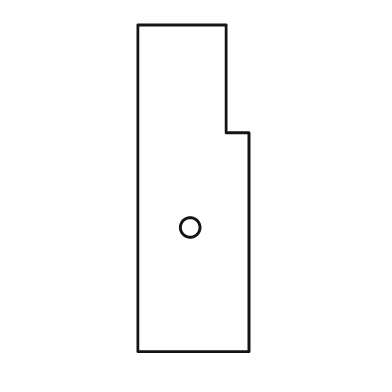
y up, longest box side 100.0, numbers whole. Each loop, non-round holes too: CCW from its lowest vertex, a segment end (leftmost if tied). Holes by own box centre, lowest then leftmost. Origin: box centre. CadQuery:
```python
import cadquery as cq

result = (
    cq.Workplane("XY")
    .moveTo(-17.0, -50.0)
    .lineTo(17.0, -50.0)
    .lineTo(17.0, 17.0)
    .lineTo(10.0, 17.0)
    .lineTo(10.0, 50.0)
    .lineTo(-17.0, 50.0)
    .close()
    .moveTo(-1.0, -12.0)
    .circle(3.0)
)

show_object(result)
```